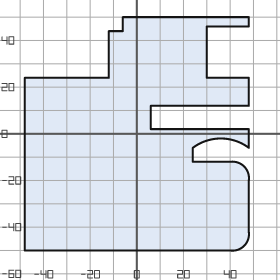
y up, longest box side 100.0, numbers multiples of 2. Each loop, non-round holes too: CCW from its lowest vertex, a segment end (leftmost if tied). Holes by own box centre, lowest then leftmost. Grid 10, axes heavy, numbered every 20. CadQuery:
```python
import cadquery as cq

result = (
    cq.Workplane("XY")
    .moveTo(-48.0, -50.0)
    .lineTo(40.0, -50.0)
    .threePointArc((46.0, -48.0), (48.0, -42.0))
    .lineTo(48.0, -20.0)
    .threePointArc((46.0, -14.0), (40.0, -12.0))
    .lineTo(24.0, -12.0)
    .lineTo(24.0, -6.0)
    .threePointArc((36.0, -2.0), (48.0, -6.0))
    .lineTo(48.0, 2.0)
    .lineTo(6.0, 2.0)
    .lineTo(6.0, 12.0)
    .lineTo(48.0, 12.0)
    .lineTo(48.0, 24.0)
    .lineTo(30.0, 24.0)
    .lineTo(30.0, 46.0)
    .lineTo(48.0, 46.0)
    .lineTo(48.0, 50.0)
    .lineTo(-6.0, 50.0)
    .lineTo(-6.0, 44.0)
    .lineTo(-12.0, 44.0)
    .lineTo(-12.0, 24.0)
    .lineTo(-48.0, 24.0)
    .close()
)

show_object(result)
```